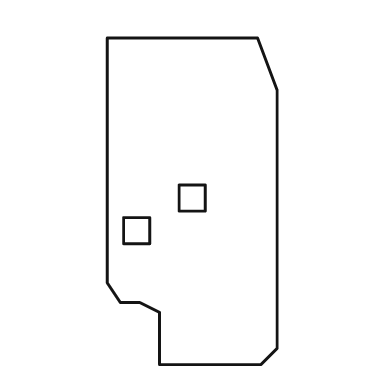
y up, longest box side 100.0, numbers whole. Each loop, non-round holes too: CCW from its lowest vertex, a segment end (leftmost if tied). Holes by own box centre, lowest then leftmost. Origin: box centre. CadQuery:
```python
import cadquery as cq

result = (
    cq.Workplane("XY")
    .moveTo(-10.0, -50.0)
    .lineTo(21.0, -50.0)
    .lineTo(26.0, -45.0)
    .lineTo(26.0, 34.0)
    .lineTo(20.0, 50.0)
    .lineTo(-26.0, 50.0)
    .lineTo(-26.0, -25.0)
    .lineTo(-22.0, -31.0)
    .lineTo(-16.0, -31.0)
    .lineTo(-10.0, -34.0)
    .close()
    .moveTo(-21.0, -13.0)
    .lineTo(-13.0, -13.0)
    .lineTo(-13.0, -5.0)
    .lineTo(-21.0, -5.0)
    .close()
    .moveTo(-4.0, -3.0)
    .lineTo(4.0, -3.0)
    .lineTo(4.0, 5.0)
    .lineTo(-4.0, 5.0)
    .close()
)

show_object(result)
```